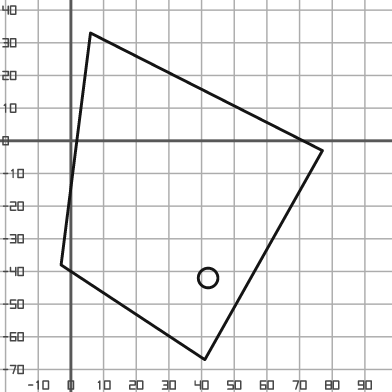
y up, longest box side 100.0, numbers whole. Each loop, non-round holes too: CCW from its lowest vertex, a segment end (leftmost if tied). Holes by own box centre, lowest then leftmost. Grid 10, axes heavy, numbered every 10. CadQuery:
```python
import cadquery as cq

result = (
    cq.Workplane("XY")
    .moveTo(41.0, -67.0)
    .lineTo(77.0, -3.0)
    .lineTo(6.0, 33.0)
    .lineTo(-3.0, -38.0)
    .close()
    .moveTo(42.0, -42.0)
    .circle(3.0)
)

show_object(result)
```